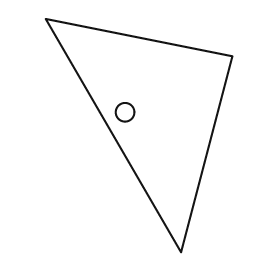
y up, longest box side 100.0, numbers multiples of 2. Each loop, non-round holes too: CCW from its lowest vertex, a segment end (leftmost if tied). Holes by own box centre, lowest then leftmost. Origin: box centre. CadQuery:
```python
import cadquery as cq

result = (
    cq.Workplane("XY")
    .moveTo(18.0, -50.0)
    .lineTo(40.0, 34.0)
    .lineTo(-40.0, 50.0)
    .close()
    .moveTo(-6.0, 10.0)
    .circle(4.0)
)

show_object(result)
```